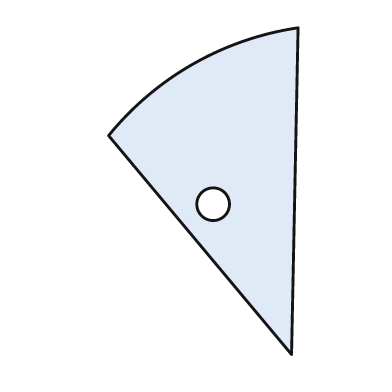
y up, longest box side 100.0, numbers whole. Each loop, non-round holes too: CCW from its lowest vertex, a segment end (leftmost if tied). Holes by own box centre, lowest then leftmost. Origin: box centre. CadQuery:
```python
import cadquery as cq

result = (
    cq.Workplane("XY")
    .moveTo(27.0, -50.0)
    .lineTo(29.0, 50.0)
    .threePointArc((-3.0, 39.0), (-29.0, 17.0))
    .close()
    .moveTo(3.0, -4.0)
    .circle(5.0)
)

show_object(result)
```